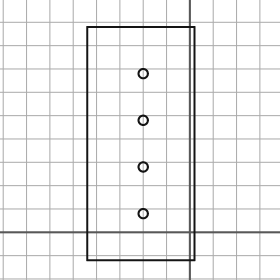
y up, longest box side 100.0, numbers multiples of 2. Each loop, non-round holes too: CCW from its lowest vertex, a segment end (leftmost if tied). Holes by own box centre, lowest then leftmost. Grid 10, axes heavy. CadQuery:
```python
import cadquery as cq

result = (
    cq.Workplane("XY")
    .moveTo(-44.0, -12.0)
    .lineTo(2.0, -12.0)
    .lineTo(2.0, 88.0)
    .lineTo(-44.0, 88.0)
    .close()
    .moveTo(-20.0, 8.0)
    .circle(2.0)
    .moveTo(-20.0, 28.0)
    .circle(2.0)
    .moveTo(-20.0, 48.0)
    .circle(2.0)
    .moveTo(-20.0, 68.0)
    .circle(2.0)
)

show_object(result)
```